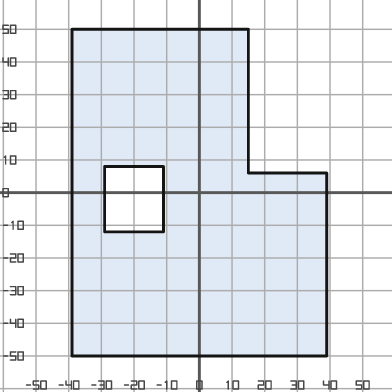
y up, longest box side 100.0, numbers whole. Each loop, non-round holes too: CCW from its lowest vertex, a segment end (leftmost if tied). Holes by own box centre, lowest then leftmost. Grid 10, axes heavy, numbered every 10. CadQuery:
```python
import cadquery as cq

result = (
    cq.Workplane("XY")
    .moveTo(-39.0, -50.0)
    .lineTo(39.0, -50.0)
    .lineTo(39.0, 6.0)
    .lineTo(15.0, 6.0)
    .lineTo(15.0, 50.0)
    .lineTo(-39.0, 50.0)
    .close()
    .moveTo(-29.0, -12.0)
    .lineTo(-11.0, -12.0)
    .lineTo(-11.0, 8.0)
    .lineTo(-29.0, 8.0)
    .close()
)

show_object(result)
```